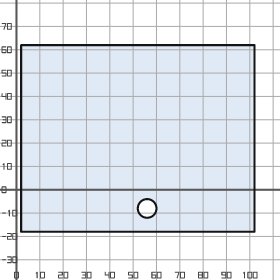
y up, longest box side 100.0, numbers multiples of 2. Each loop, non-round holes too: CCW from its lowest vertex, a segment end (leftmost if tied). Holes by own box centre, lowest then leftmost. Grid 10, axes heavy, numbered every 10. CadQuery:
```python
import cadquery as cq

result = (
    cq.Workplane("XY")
    .moveTo(2.0, -18.0)
    .lineTo(102.0, -18.0)
    .lineTo(102.0, 62.0)
    .lineTo(2.0, 62.0)
    .close()
    .moveTo(56.0, -8.0)
    .circle(4.0)
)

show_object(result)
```